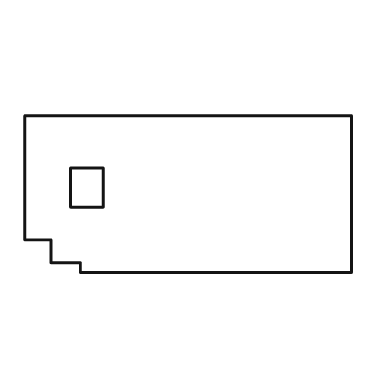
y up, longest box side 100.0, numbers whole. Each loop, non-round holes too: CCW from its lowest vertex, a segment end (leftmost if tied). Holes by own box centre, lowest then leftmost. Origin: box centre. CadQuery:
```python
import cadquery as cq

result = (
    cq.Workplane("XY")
    .moveTo(-33.0, -24.0)
    .lineTo(50.0, -24.0)
    .lineTo(50.0, 24.0)
    .lineTo(-50.0, 24.0)
    .lineTo(-50.0, -14.0)
    .lineTo(-42.0, -14.0)
    .lineTo(-42.0, -21.0)
    .lineTo(-33.0, -21.0)
    .close()
    .moveTo(-36.0, -4.0)
    .lineTo(-26.0, -4.0)
    .lineTo(-26.0, 8.0)
    .lineTo(-36.0, 8.0)
    .close()
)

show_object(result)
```